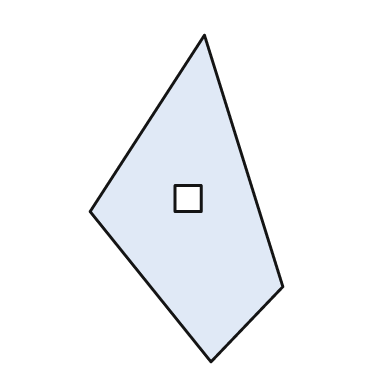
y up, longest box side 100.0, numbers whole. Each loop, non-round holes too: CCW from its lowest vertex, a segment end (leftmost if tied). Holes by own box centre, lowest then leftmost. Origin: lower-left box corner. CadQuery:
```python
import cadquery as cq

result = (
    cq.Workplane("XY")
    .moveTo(37.0, 0.0)
    .lineTo(59.0, 23.0)
    .lineTo(35.0, 100.0)
    .lineTo(0.0, 46.0)
    .close()
    .moveTo(26.0, 46.0)
    .lineTo(34.0, 46.0)
    .lineTo(34.0, 54.0)
    .lineTo(26.0, 54.0)
    .close()
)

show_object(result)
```